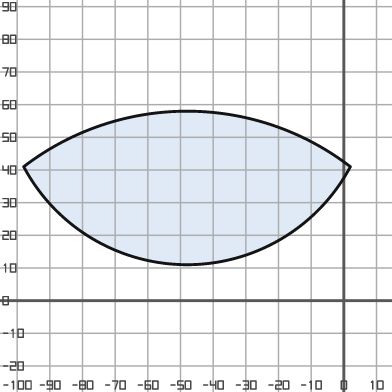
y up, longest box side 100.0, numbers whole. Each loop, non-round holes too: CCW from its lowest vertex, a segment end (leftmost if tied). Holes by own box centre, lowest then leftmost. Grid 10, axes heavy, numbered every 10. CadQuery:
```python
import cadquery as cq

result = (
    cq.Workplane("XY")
    .moveTo(-98.0, 41.0)
    .threePointArc((-48.0, 11.0), (2.0, 41.0))
    .threePointArc((-48.0, 58.0), (-98.0, 41.0))
    .close()
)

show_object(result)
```